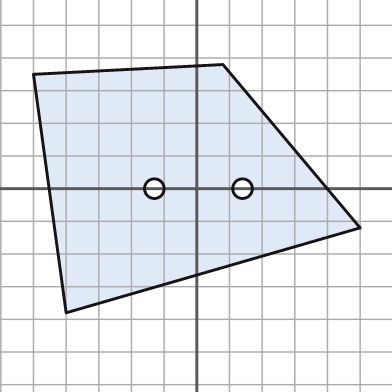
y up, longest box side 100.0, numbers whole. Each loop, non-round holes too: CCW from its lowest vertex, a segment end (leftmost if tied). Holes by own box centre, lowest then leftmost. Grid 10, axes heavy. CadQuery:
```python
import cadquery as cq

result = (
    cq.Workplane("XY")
    .moveTo(-40.0, -38.0)
    .lineTo(50.0, -12.0)
    .lineTo(8.0, 38.0)
    .lineTo(-50.0, 35.0)
    .close()
    .moveTo(-13.0, 0.0)
    .circle(3.0)
    .moveTo(14.0, 0.0)
    .circle(3.0)
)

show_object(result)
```